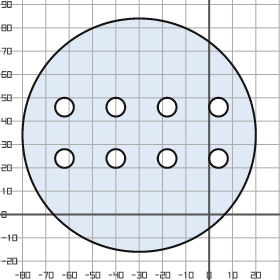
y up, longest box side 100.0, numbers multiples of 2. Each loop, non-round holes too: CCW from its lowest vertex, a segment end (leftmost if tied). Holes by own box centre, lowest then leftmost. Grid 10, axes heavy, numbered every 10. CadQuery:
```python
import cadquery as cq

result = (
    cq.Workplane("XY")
    .moveTo(-30.0, 34.0)
    .circle(50.0)
    .moveTo(-62.0, 24.0)
    .circle(4.0)
    .moveTo(-40.0, 24.0)
    .circle(4.0)
    .moveTo(-18.0, 24.0)
    .circle(4.0)
    .moveTo(4.0, 24.0)
    .circle(4.0)
    .moveTo(-62.0, 46.0)
    .circle(4.0)
    .moveTo(-40.0, 46.0)
    .circle(4.0)
    .moveTo(-18.0, 46.0)
    .circle(4.0)
    .moveTo(4.0, 46.0)
    .circle(4.0)
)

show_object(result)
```